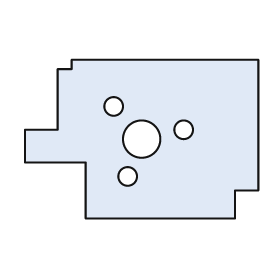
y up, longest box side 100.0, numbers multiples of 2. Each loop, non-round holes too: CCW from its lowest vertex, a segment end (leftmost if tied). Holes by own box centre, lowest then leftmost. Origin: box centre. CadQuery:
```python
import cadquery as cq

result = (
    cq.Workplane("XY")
    .moveTo(-24.0, -34.0)
    .lineTo(40.0, -34.0)
    .lineTo(40.0, -22.0)
    .lineTo(50.0, -22.0)
    .lineTo(50.0, 34.0)
    .lineTo(-30.0, 34.0)
    .lineTo(-30.0, 30.0)
    .lineTo(-36.0, 30.0)
    .lineTo(-36.0, 4.0)
    .lineTo(-50.0, 4.0)
    .lineTo(-50.0, -10.0)
    .lineTo(-24.0, -10.0)
    .close()
    .moveTo(-6.0, -16.0)
    .circle(4.0)
    .moveTo(0.0, 0.0)
    .circle(8.0)
    .moveTo(18.0, 4.0)
    .circle(4.0)
    .moveTo(-12.0, 14.0)
    .circle(4.0)
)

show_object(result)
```